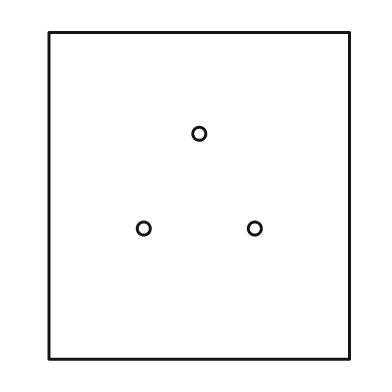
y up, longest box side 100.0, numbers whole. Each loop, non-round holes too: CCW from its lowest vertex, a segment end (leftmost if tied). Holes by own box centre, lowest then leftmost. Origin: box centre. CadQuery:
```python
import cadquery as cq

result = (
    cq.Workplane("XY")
    .moveTo(-46.0, -50.0)
    .lineTo(46.0, -50.0)
    .lineTo(46.0, 50.0)
    .lineTo(-46.0, 50.0)
    .close()
    .moveTo(-17.0, -10.0)
    .circle(2.0)
    .moveTo(17.0, -10.0)
    .circle(2.0)
    .moveTo(0.0, 19.0)
    .circle(2.0)
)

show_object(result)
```